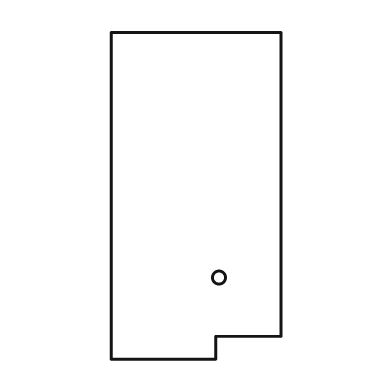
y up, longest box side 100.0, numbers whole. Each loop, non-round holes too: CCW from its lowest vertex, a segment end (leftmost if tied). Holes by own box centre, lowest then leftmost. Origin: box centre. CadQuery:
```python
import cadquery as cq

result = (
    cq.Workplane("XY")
    .moveTo(-26.0, -50.0)
    .lineTo(6.0, -50.0)
    .lineTo(6.0, -43.0)
    .lineTo(26.0, -43.0)
    .lineTo(26.0, 50.0)
    .lineTo(-26.0, 50.0)
    .close()
    .moveTo(7.0, -25.0)
    .circle(2.0)
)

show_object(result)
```